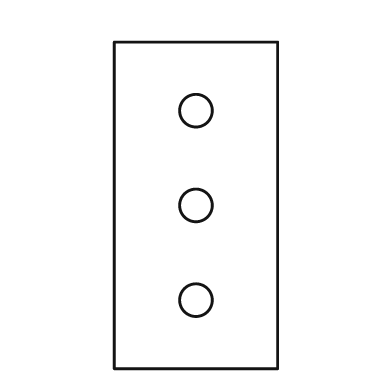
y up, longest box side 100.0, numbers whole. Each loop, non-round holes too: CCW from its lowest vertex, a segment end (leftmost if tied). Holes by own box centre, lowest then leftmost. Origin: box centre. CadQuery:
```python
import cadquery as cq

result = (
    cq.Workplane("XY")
    .moveTo(-25.0, -50.0)
    .lineTo(25.0, -50.0)
    .lineTo(25.0, 50.0)
    .lineTo(-25.0, 50.0)
    .close()
    .moveTo(0.0, -29.0)
    .circle(5.0)
    .moveTo(0.0, 0.0)
    .circle(5.0)
    .moveTo(0.0, 29.0)
    .circle(5.0)
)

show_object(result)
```